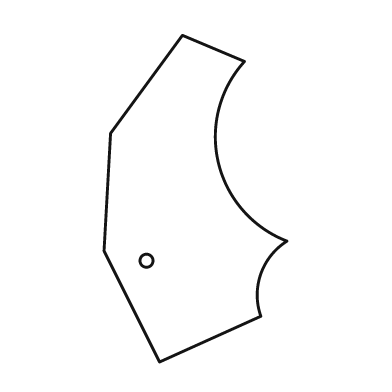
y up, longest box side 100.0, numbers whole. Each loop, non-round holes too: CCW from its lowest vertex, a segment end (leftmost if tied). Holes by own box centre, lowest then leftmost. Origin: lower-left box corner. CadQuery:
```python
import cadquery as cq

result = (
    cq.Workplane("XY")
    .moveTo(17.0, 0.0)
    .lineTo(48.0, 14.0)
    .threePointArc((48.0, 27.0), (56.0, 37.0))
    .threePointArc((35.0, 61.0), (43.0, 92.0))
    .lineTo(24.0, 100.0)
    .lineTo(2.0, 70.0)
    .lineTo(0.0, 34.0)
    .close()
    .moveTo(13.0, 31.0)
    .circle(2.0)
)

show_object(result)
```